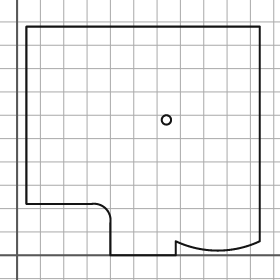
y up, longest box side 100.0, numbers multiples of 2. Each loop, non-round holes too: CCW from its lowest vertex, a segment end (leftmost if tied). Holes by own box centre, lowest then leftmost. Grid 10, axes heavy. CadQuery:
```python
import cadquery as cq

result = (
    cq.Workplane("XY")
    .moveTo(40.0, 0.0)
    .lineTo(68.0, 0.0)
    .lineTo(68.0, 6.0)
    .threePointArc((86.0, 2.0), (104.0, 6.0))
    .lineTo(104.0, 98.0)
    .lineTo(4.0, 98.0)
    .lineTo(4.0, 22.0)
    .lineTo(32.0, 22.0)
    .threePointArc((38.0, 20.0), (40.0, 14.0))
    .close()
    .moveTo(64.0, 58.0)
    .circle(2.0)
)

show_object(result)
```